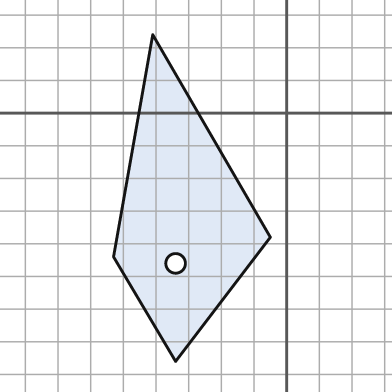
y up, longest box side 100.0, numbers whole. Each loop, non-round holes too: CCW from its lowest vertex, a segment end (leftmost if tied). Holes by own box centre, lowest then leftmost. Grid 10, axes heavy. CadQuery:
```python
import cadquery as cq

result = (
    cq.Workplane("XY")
    .moveTo(-34.0, -76.0)
    .lineTo(-5.0, -38.0)
    .lineTo(-41.0, 24.0)
    .lineTo(-53.0, -44.0)
    .close()
    .moveTo(-34.0, -46.0)
    .circle(3.0)
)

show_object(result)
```